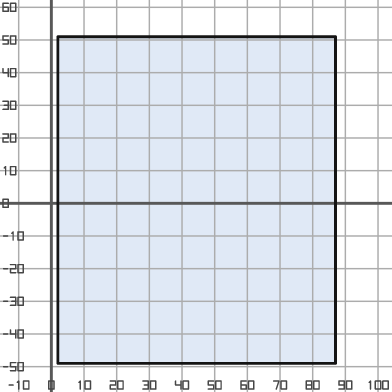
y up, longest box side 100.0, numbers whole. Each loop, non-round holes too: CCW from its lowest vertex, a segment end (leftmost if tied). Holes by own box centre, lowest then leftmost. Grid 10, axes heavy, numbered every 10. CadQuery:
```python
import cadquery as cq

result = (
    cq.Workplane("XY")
    .moveTo(2.0, -49.0)
    .lineTo(87.0, -49.0)
    .lineTo(87.0, 51.0)
    .lineTo(2.0, 51.0)
    .close()
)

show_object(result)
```